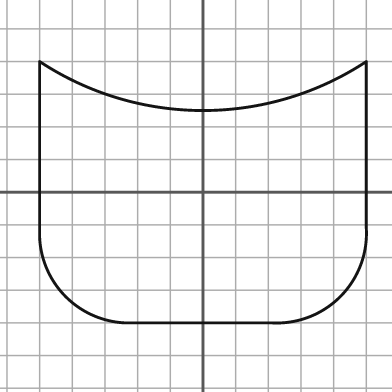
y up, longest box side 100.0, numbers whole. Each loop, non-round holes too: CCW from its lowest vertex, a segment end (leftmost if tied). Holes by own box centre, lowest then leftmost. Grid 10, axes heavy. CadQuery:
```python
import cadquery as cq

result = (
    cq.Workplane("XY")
    .moveTo(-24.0, -40.0)
    .lineTo(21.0, -40.0)
    .threePointArc((42.0, -32.0), (50.0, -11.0))
    .lineTo(50.0, 40.0)
    .threePointArc((0.0, 25.0), (-50.0, 40.0))
    .lineTo(-50.0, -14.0)
    .threePointArc((-42.0, -32.0), (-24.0, -40.0))
    .close()
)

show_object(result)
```